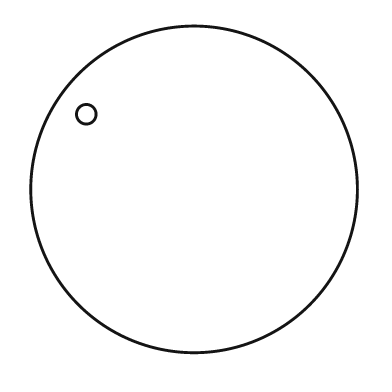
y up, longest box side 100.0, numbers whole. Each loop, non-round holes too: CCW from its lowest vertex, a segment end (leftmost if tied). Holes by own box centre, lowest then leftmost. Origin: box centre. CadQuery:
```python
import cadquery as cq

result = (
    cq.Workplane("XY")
    .moveTo(0.0, 0.0)
    .circle(50.0)
    .moveTo(-33.0, 23.0)
    .circle(3.0)
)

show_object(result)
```